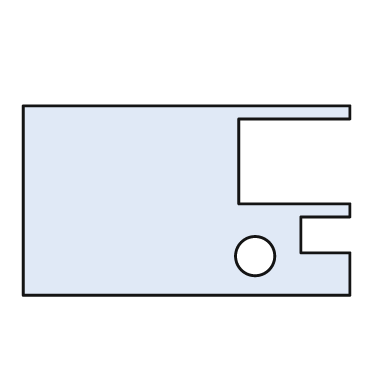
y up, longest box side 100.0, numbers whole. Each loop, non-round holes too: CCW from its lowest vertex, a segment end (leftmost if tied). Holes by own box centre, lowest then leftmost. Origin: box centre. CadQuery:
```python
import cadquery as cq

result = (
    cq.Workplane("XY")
    .moveTo(-50.0, -29.0)
    .lineTo(50.0, -29.0)
    .lineTo(50.0, -16.0)
    .lineTo(35.0, -16.0)
    .lineTo(35.0, -5.0)
    .lineTo(50.0, -5.0)
    .lineTo(50.0, -1.0)
    .lineTo(16.0, -1.0)
    .lineTo(16.0, 25.0)
    .lineTo(50.0, 25.0)
    .lineTo(50.0, 29.0)
    .lineTo(-50.0, 29.0)
    .close()
    .moveTo(21.0, -17.0)
    .circle(6.0)
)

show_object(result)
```